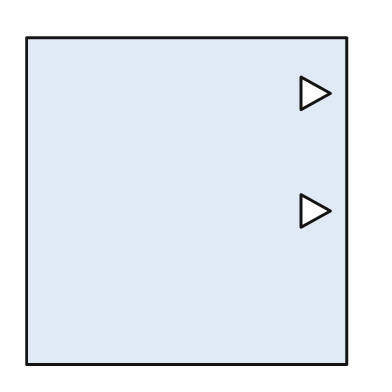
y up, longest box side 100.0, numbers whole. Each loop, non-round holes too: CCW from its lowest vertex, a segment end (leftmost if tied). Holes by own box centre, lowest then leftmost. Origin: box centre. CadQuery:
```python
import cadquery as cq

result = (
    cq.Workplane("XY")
    .moveTo(-49.0, -50.0)
    .lineTo(49.0, -50.0)
    .lineTo(49.0, 50.0)
    .lineTo(-49.0, 50.0)
    .close()
    .moveTo(35.0, -8.0)
    .lineTo(44.0, -3.0)
    .lineTo(35.0, 2.0)
    .close()
    .moveTo(35.0, 28.0)
    .lineTo(44.0, 33.0)
    .lineTo(35.0, 38.0)
    .close()
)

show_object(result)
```